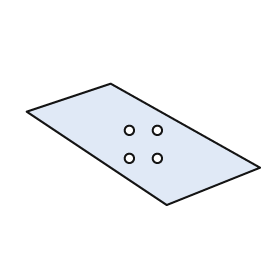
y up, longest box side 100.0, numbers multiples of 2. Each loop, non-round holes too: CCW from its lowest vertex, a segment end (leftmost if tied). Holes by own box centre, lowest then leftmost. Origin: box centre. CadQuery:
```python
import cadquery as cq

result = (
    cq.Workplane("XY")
    .moveTo(10.0, -26.0)
    .lineTo(50.0, -10.0)
    .lineTo(-14.0, 26.0)
    .lineTo(-50.0, 14.0)
    .close()
    .moveTo(-6.0, -6.0)
    .circle(2.0)
    .moveTo(6.0, -6.0)
    .circle(2.0)
    .moveTo(-6.0, 6.0)
    .circle(2.0)
    .moveTo(6.0, 6.0)
    .circle(2.0)
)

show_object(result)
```